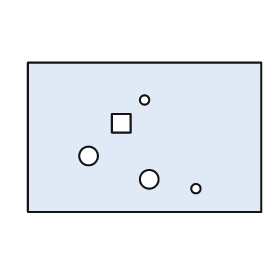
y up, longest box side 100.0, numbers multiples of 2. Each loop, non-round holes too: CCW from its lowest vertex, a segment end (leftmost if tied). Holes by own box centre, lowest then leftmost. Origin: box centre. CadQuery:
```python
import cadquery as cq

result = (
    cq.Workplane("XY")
    .moveTo(-50.0, -32.0)
    .lineTo(50.0, -32.0)
    .lineTo(50.0, 32.0)
    .lineTo(-50.0, 32.0)
    .close()
    .moveTo(22.0, -22.0)
    .circle(2.0)
    .moveTo(2.0, -18.0)
    .circle(4.0)
    .moveTo(-24.0, -8.0)
    .circle(4.0)
    .moveTo(-14.0, 2.0)
    .lineTo(-6.0, 2.0)
    .lineTo(-6.0, 10.0)
    .lineTo(-14.0, 10.0)
    .close()
    .moveTo(0.0, 16.0)
    .circle(2.0)
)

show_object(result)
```